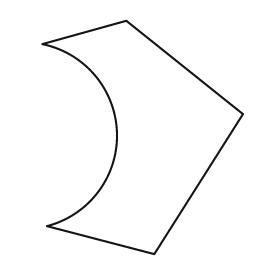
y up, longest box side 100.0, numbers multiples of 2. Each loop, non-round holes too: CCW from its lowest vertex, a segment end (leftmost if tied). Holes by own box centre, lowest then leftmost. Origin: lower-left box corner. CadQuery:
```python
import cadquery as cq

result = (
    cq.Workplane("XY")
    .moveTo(48.0, 0.0)
    .lineTo(86.0, 60.0)
    .lineTo(36.0, 100.0)
    .lineTo(0.0, 90.0)
    .threePointArc((32.0, 52.0), (2.0, 12.0))
    .close()
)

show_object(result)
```